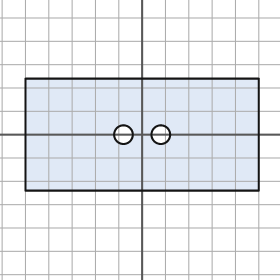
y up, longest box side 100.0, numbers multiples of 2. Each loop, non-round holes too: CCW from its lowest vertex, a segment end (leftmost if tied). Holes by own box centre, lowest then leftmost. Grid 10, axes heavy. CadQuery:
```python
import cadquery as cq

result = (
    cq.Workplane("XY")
    .moveTo(-50.0, -24.0)
    .lineTo(50.0, -24.0)
    .lineTo(50.0, 24.0)
    .lineTo(-50.0, 24.0)
    .close()
    .moveTo(-8.0, 0.0)
    .circle(4.0)
    .moveTo(8.0, 0.0)
    .circle(4.0)
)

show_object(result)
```